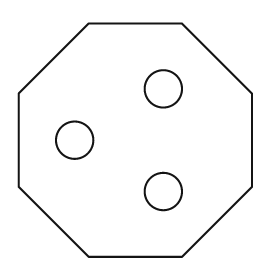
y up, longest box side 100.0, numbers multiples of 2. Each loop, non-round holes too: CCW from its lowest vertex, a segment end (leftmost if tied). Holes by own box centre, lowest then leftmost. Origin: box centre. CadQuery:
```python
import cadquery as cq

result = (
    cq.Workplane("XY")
    .moveTo(-20.0, -50.0)
    .lineTo(20.0, -50.0)
    .lineTo(50.0, -20.0)
    .lineTo(50.0, 20.0)
    .lineTo(20.0, 50.0)
    .lineTo(-20.0, 50.0)
    .lineTo(-50.0, 20.0)
    .lineTo(-50.0, -20.0)
    .close()
    .moveTo(12.0, -22.0)
    .circle(8.0)
    .moveTo(-26.0, 0.0)
    .circle(8.0)
    .moveTo(12.0, 22.0)
    .circle(8.0)
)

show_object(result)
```